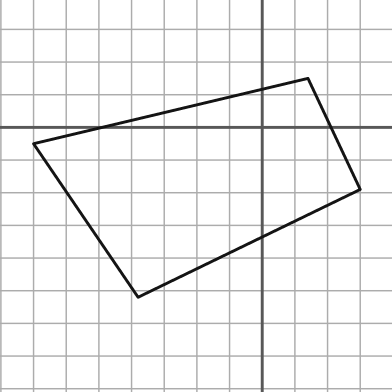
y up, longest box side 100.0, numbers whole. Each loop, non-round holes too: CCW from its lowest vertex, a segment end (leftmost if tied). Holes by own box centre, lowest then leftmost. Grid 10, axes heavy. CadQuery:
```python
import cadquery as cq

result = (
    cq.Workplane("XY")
    .moveTo(-38.0, -52.0)
    .lineTo(30.0, -19.0)
    .lineTo(14.0, 15.0)
    .lineTo(-70.0, -5.0)
    .close()
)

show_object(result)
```